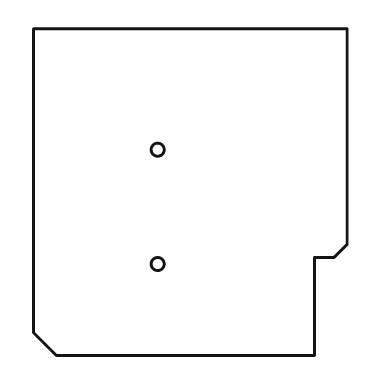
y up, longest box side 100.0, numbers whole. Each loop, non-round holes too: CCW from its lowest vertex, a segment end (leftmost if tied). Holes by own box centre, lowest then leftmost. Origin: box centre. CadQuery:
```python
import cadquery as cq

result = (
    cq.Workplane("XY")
    .moveTo(-41.0, -50.0)
    .lineTo(38.0, -50.0)
    .lineTo(38.0, -20.0)
    .lineTo(44.0, -20.0)
    .lineTo(48.0, -16.0)
    .lineTo(48.0, 50.0)
    .lineTo(-48.0, 50.0)
    .lineTo(-48.0, -43.0)
    .close()
    .moveTo(-10.0, -22.0)
    .circle(2.0)
    .moveTo(-10.0, 13.0)
    .circle(2.0)
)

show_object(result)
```